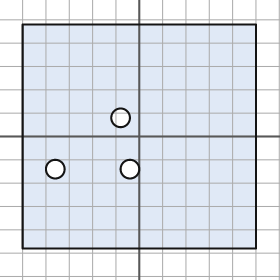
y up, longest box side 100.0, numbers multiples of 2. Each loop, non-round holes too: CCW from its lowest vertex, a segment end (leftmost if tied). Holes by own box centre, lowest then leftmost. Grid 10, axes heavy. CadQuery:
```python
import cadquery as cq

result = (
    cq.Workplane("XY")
    .moveTo(-50.0, -48.0)
    .lineTo(50.0, -48.0)
    .lineTo(50.0, 48.0)
    .lineTo(-50.0, 48.0)
    .close()
    .moveTo(-36.0, -14.0)
    .circle(4.0)
    .moveTo(-4.0, -14.0)
    .circle(4.0)
    .moveTo(-8.0, 8.0)
    .circle(4.0)
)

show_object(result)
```